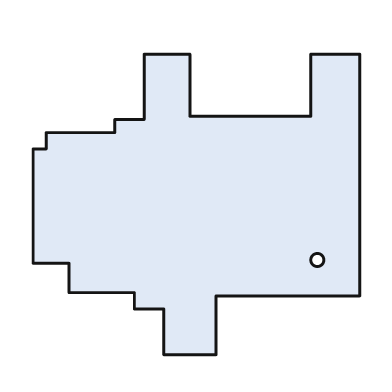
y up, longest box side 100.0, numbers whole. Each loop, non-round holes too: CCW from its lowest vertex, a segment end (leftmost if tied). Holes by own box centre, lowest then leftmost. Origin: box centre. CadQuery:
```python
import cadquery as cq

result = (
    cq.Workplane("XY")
    .moveTo(-10.0, -46.0)
    .lineTo(6.0, -46.0)
    .lineTo(6.0, -28.0)
    .lineTo(50.0, -28.0)
    .lineTo(50.0, 46.0)
    .lineTo(35.0, 46.0)
    .lineTo(35.0, 27.0)
    .lineTo(-2.0, 27.0)
    .lineTo(-2.0, 46.0)
    .lineTo(-16.0, 46.0)
    .lineTo(-16.0, 26.0)
    .lineTo(-25.0, 26.0)
    .lineTo(-25.0, 22.0)
    .lineTo(-46.0, 22.0)
    .lineTo(-46.0, 17.0)
    .lineTo(-50.0, 17.0)
    .lineTo(-50.0, -18.0)
    .lineTo(-39.0, -18.0)
    .lineTo(-39.0, -27.0)
    .lineTo(-19.0, -27.0)
    .lineTo(-19.0, -32.0)
    .lineTo(-10.0, -32.0)
    .close()
    .moveTo(37.0, -17.0)
    .circle(2.0)
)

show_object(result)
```